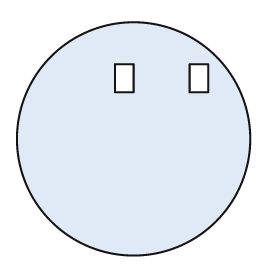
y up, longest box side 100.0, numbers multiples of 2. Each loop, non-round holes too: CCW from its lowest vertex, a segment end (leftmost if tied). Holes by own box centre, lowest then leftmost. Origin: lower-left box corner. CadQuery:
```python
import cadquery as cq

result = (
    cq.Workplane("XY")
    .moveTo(50.0, 50.0)
    .circle(50.0)
    .moveTo(42.0, 70.0)
    .lineTo(50.0, 70.0)
    .lineTo(50.0, 82.0)
    .lineTo(42.0, 82.0)
    .close()
    .moveTo(74.0, 70.0)
    .lineTo(82.0, 70.0)
    .lineTo(82.0, 82.0)
    .lineTo(74.0, 82.0)
    .close()
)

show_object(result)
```